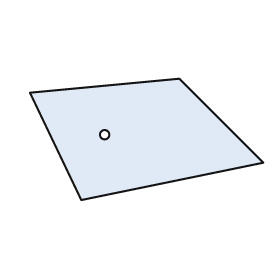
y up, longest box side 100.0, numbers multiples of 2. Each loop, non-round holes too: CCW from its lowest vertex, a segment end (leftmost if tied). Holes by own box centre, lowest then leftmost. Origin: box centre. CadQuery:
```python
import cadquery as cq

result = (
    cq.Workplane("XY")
    .moveTo(-28.0, -26.0)
    .lineTo(50.0, -10.0)
    .lineTo(14.0, 26.0)
    .lineTo(-50.0, 20.0)
    .close()
    .moveTo(-18.0, 2.0)
    .circle(2.0)
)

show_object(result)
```